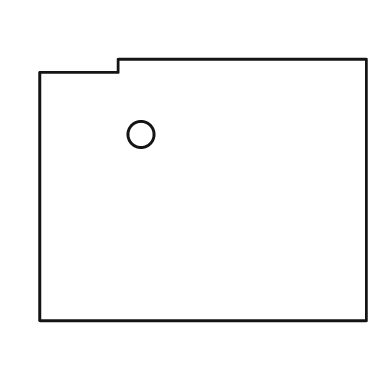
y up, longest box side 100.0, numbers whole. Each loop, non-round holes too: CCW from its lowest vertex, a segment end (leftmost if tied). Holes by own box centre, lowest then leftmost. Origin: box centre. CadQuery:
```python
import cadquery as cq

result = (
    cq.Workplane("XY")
    .moveTo(-50.0, -40.0)
    .lineTo(50.0, -40.0)
    .lineTo(50.0, 40.0)
    .lineTo(-26.0, 40.0)
    .lineTo(-26.0, 36.0)
    .lineTo(-50.0, 36.0)
    .close()
    .moveTo(-19.0, 17.0)
    .circle(4.0)
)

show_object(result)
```